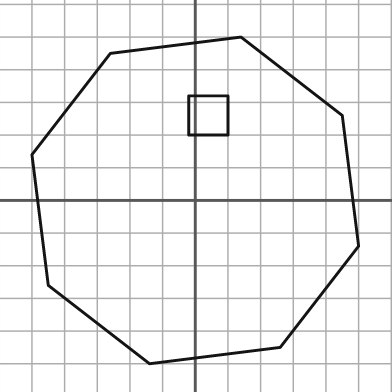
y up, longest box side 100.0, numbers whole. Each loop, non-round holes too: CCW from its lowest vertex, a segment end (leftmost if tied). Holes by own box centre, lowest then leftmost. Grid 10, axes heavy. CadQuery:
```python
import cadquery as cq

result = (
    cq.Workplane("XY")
    .moveTo(-14.0, -50.0)
    .lineTo(26.0, -45.0)
    .lineTo(50.0, -14.0)
    .lineTo(45.0, 26.0)
    .lineTo(14.0, 50.0)
    .lineTo(-26.0, 45.0)
    .lineTo(-50.0, 14.0)
    .lineTo(-45.0, -26.0)
    .close()
    .moveTo(-2.0, 20.0)
    .lineTo(10.0, 20.0)
    .lineTo(10.0, 32.0)
    .lineTo(-2.0, 32.0)
    .close()
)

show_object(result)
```